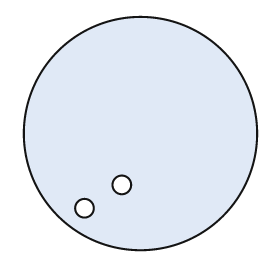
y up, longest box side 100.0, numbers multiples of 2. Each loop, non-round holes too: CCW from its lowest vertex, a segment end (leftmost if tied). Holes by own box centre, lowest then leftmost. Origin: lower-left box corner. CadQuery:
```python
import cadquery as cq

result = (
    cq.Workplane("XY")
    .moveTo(50.0, 50.0)
    .circle(50.0)
    .moveTo(26.0, 18.0)
    .circle(4.0)
    .moveTo(42.0, 28.0)
    .circle(4.0)
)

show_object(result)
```